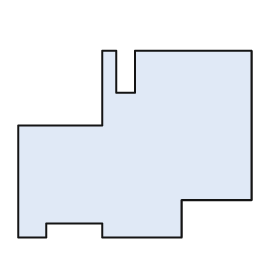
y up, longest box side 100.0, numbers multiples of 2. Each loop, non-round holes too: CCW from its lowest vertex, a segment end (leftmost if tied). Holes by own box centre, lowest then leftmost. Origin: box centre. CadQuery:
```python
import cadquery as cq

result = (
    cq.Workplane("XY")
    .moveTo(-50.0, -40.0)
    .lineTo(-38.0, -40.0)
    .lineTo(-38.0, -34.0)
    .lineTo(-14.0, -34.0)
    .lineTo(-14.0, -40.0)
    .lineTo(20.0, -40.0)
    .lineTo(20.0, -24.0)
    .lineTo(50.0, -24.0)
    .lineTo(50.0, 40.0)
    .lineTo(0.0, 40.0)
    .lineTo(0.0, 22.0)
    .lineTo(-8.0, 22.0)
    .lineTo(-8.0, 40.0)
    .lineTo(-14.0, 40.0)
    .lineTo(-14.0, 8.0)
    .lineTo(-50.0, 8.0)
    .close()
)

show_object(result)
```